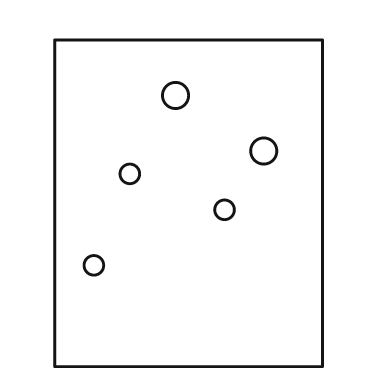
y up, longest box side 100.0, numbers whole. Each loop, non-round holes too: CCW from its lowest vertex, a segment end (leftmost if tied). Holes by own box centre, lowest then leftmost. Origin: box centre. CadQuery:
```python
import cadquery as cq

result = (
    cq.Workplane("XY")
    .moveTo(-41.0, -50.0)
    .lineTo(41.0, -50.0)
    .lineTo(41.0, 50.0)
    .lineTo(-41.0, 50.0)
    .close()
    .moveTo(-29.0, -19.0)
    .circle(3.0)
    .moveTo(11.0, -2.0)
    .circle(3.0)
    .moveTo(-18.0, 9.0)
    .circle(3.0)
    .moveTo(23.0, 16.0)
    .circle(4.0)
    .moveTo(-4.0, 33.0)
    .circle(4.0)
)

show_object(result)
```